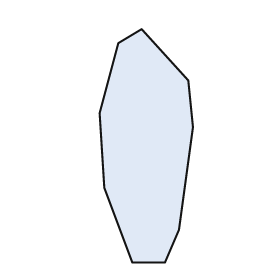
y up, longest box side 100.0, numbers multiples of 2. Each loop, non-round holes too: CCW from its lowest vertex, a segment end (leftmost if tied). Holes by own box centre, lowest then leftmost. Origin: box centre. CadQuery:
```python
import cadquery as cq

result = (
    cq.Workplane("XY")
    .moveTo(-6.0, -50.0)
    .lineTo(8.0, -50.0)
    .lineTo(14.0, -36.0)
    .lineTo(20.0, 8.0)
    .lineTo(18.0, 28.0)
    .lineTo(-2.0, 50.0)
    .lineTo(-12.0, 44.0)
    .lineTo(-20.0, 14.0)
    .lineTo(-18.0, -18.0)
    .close()
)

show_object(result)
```